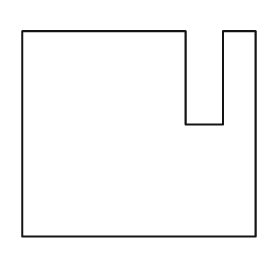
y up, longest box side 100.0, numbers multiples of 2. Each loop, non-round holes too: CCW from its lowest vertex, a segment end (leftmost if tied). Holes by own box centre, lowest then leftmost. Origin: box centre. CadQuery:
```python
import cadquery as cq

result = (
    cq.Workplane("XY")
    .moveTo(-50.0, -44.0)
    .lineTo(50.0, -44.0)
    .lineTo(50.0, 44.0)
    .lineTo(36.0, 44.0)
    .lineTo(36.0, 4.0)
    .lineTo(20.0, 4.0)
    .lineTo(20.0, 44.0)
    .lineTo(-50.0, 44.0)
    .close()
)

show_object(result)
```